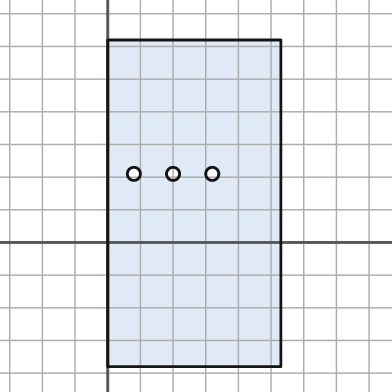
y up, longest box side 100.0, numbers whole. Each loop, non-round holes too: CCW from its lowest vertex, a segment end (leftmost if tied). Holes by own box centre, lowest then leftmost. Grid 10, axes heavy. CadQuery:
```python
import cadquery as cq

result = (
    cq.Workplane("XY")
    .moveTo(0.0, -38.0)
    .lineTo(53.0, -38.0)
    .lineTo(53.0, 62.0)
    .lineTo(0.0, 62.0)
    .close()
    .moveTo(8.0, 21.0)
    .circle(2.0)
    .moveTo(20.0, 21.0)
    .circle(2.0)
    .moveTo(32.0, 21.0)
    .circle(2.0)
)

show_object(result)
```